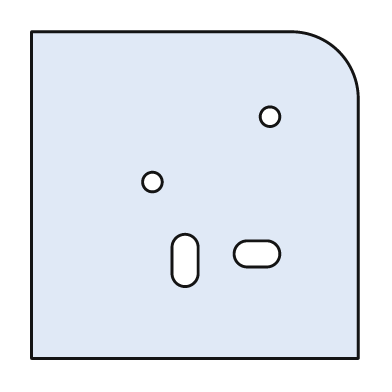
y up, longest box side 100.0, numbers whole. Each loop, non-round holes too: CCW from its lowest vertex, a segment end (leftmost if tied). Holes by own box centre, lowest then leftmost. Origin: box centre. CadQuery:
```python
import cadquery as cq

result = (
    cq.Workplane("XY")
    .moveTo(-50.0, -50.0)
    .lineTo(50.0, -50.0)
    .lineTo(50.0, 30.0)
    .threePointArc((44.0, 44.0), (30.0, 50.0))
    .lineTo(-50.0, 50.0)
    .close()
    .moveTo(-7.0, -24.0)
    .threePointArc((-3.0, -28.0), (1.0, -24.0))
    .lineTo(1.0, -16.0)
    .threePointArc((-3.0, -12.0), (-7.0, -16.0))
    .close()
    .moveTo(16.0, -22.0)
    .lineTo(22.0, -22.0)
    .threePointArc((26.0, -18.0), (22.0, -14.0))
    .lineTo(16.0, -14.0)
    .threePointArc((12.0, -18.0), (16.0, -22.0))
    .close()
    .moveTo(-13.0, 4.0)
    .circle(3.0)
    .moveTo(23.0, 24.0)
    .circle(3.0)
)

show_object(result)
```